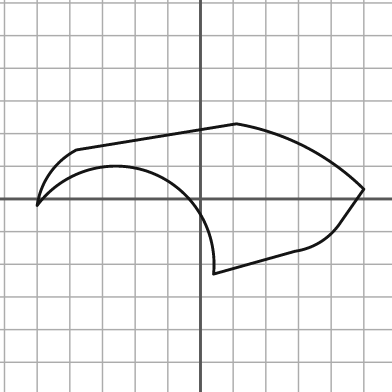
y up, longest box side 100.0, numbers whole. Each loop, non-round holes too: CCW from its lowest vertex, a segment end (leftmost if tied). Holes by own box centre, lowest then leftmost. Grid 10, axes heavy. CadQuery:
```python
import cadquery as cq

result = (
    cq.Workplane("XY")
    .moveTo(4.0, -23.0)
    .lineTo(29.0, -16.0)
    .threePointArc((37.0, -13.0), (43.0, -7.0))
    .lineTo(50.0, 3.0)
    .threePointArc((32.0, 16.0), (11.0, 23.0))
    .lineTo(-38.0, 15.0)
    .threePointArc((-46.0, 8.0), (-50.0, -2.0))
    .threePointArc((-15.0, 8.0), (4.0, -23.0))
    .close()
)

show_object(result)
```